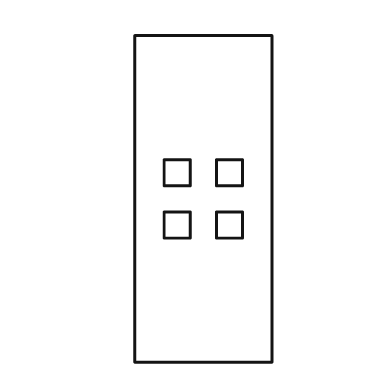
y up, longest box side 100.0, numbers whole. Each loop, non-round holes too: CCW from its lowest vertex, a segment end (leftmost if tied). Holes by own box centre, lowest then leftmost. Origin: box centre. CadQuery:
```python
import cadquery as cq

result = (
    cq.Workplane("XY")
    .moveTo(-21.0, -50.0)
    .lineTo(21.0, -50.0)
    .lineTo(21.0, 50.0)
    .lineTo(-21.0, 50.0)
    .close()
    .moveTo(-12.0, -12.0)
    .lineTo(-4.0, -12.0)
    .lineTo(-4.0, -4.0)
    .lineTo(-12.0, -4.0)
    .close()
    .moveTo(4.0, -12.0)
    .lineTo(12.0, -12.0)
    .lineTo(12.0, -4.0)
    .lineTo(4.0, -4.0)
    .close()
    .moveTo(-12.0, 4.0)
    .lineTo(-4.0, 4.0)
    .lineTo(-4.0, 12.0)
    .lineTo(-12.0, 12.0)
    .close()
    .moveTo(4.0, 4.0)
    .lineTo(12.0, 4.0)
    .lineTo(12.0, 12.0)
    .lineTo(4.0, 12.0)
    .close()
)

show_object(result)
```